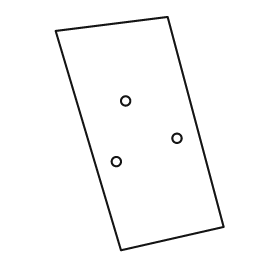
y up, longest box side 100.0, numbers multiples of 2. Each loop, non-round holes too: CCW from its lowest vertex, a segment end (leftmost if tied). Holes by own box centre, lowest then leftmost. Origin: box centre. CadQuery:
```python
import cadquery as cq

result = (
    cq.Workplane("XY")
    .moveTo(-8.0, -50.0)
    .lineTo(36.0, -40.0)
    .lineTo(12.0, 50.0)
    .lineTo(-36.0, 44.0)
    .close()
    .moveTo(-10.0, -12.0)
    .circle(2.0)
    .moveTo(16.0, -2.0)
    .circle(2.0)
    .moveTo(-6.0, 14.0)
    .circle(2.0)
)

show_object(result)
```